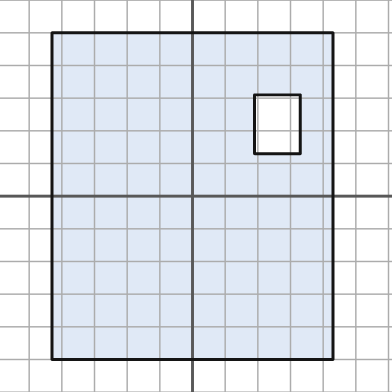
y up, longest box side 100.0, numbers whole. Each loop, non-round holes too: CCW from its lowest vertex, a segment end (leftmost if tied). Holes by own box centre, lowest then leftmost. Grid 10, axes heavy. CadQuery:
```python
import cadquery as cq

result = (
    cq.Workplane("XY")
    .moveTo(-43.0, -50.0)
    .lineTo(43.0, -50.0)
    .lineTo(43.0, 50.0)
    .lineTo(-43.0, 50.0)
    .close()
    .moveTo(19.0, 13.0)
    .lineTo(33.0, 13.0)
    .lineTo(33.0, 31.0)
    .lineTo(19.0, 31.0)
    .close()
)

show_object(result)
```